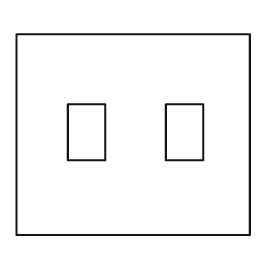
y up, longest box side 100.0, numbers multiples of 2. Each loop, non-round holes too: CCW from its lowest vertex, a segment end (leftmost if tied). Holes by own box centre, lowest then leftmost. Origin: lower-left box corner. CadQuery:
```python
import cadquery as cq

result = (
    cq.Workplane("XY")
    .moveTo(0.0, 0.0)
    .lineTo(100.0, 0.0)
    .lineTo(100.0, 86.0)
    .lineTo(0.0, 86.0)
    .close()
    .moveTo(22.0, 32.0)
    .lineTo(38.0, 32.0)
    .lineTo(38.0, 56.0)
    .lineTo(22.0, 56.0)
    .close()
    .moveTo(64.0, 32.0)
    .lineTo(80.0, 32.0)
    .lineTo(80.0, 56.0)
    .lineTo(64.0, 56.0)
    .close()
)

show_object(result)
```